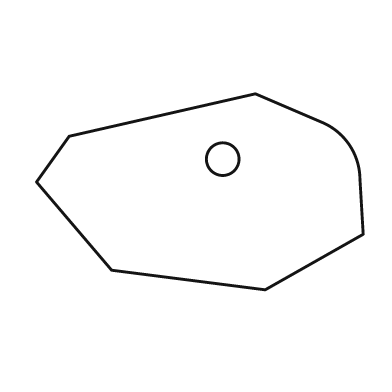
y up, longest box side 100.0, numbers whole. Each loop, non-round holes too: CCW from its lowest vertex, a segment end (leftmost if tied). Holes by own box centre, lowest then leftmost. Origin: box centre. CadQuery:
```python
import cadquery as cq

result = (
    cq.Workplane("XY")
    .moveTo(20.0, -30.0)
    .lineTo(50.0, -13.0)
    .lineTo(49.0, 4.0)
    .threePointArc((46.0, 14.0), (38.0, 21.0))
    .lineTo(17.0, 30.0)
    .lineTo(-40.0, 17.0)
    .lineTo(-50.0, 3.0)
    .lineTo(-27.0, -24.0)
    .close()
    .moveTo(7.0, 10.0)
    .circle(5.0)
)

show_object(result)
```